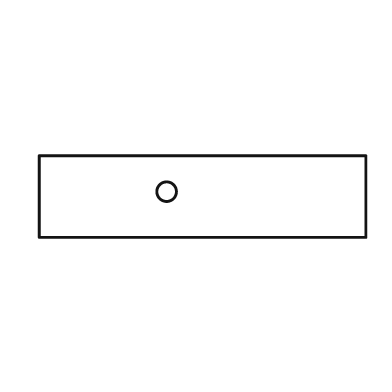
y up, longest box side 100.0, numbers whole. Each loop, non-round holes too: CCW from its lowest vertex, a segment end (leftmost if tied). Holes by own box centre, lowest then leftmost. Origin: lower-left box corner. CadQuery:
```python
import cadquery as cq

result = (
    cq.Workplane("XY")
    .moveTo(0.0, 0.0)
    .lineTo(100.0, 0.0)
    .lineTo(100.0, 25.0)
    .lineTo(0.0, 25.0)
    .close()
    .moveTo(39.0, 14.0)
    .circle(3.0)
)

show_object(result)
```